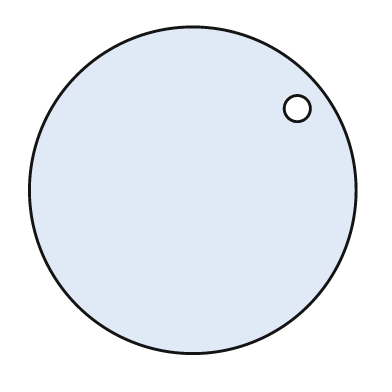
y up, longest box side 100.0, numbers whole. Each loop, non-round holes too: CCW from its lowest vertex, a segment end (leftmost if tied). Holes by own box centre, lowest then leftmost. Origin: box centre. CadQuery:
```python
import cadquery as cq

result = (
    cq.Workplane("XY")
    .moveTo(0.0, 0.0)
    .circle(50.0)
    .moveTo(32.0, 25.0)
    .circle(4.0)
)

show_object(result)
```